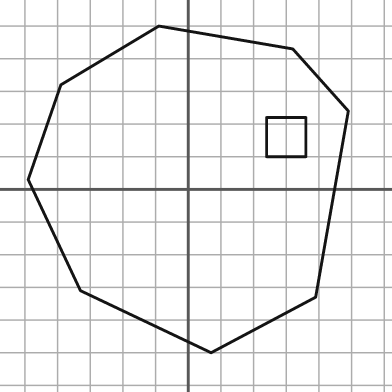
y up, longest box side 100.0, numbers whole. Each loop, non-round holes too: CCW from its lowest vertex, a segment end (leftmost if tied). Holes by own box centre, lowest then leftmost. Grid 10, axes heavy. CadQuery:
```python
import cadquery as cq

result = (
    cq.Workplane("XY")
    .moveTo(7.0, -50.0)
    .lineTo(39.0, -33.0)
    .lineTo(49.0, 24.0)
    .lineTo(32.0, 43.0)
    .lineTo(-9.0, 50.0)
    .lineTo(-39.0, 32.0)
    .lineTo(-49.0, 3.0)
    .lineTo(-33.0, -31.0)
    .close()
    .moveTo(24.0, 10.0)
    .lineTo(36.0, 10.0)
    .lineTo(36.0, 22.0)
    .lineTo(24.0, 22.0)
    .close()
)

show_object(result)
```